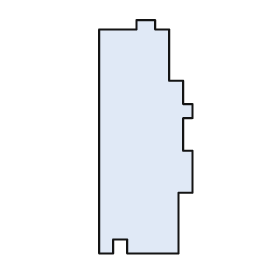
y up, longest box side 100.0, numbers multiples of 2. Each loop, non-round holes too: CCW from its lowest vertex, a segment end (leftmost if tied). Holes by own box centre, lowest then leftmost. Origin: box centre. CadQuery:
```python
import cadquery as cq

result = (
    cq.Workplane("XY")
    .moveTo(-20.0, -50.0)
    .lineTo(-14.0, -50.0)
    .lineTo(-14.0, -44.0)
    .lineTo(-8.0, -44.0)
    .lineTo(-8.0, -50.0)
    .lineTo(14.0, -50.0)
    .lineTo(14.0, -24.0)
    .lineTo(20.0, -24.0)
    .lineTo(20.0, -6.0)
    .lineTo(16.0, -6.0)
    .lineTo(16.0, 8.0)
    .lineTo(20.0, 8.0)
    .lineTo(20.0, 14.0)
    .lineTo(16.0, 14.0)
    .lineTo(16.0, 24.0)
    .lineTo(10.0, 24.0)
    .lineTo(10.0, 46.0)
    .lineTo(4.0, 46.0)
    .lineTo(4.0, 50.0)
    .lineTo(-4.0, 50.0)
    .lineTo(-4.0, 46.0)
    .lineTo(-20.0, 46.0)
    .close()
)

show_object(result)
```